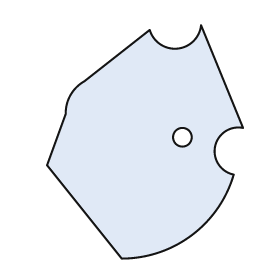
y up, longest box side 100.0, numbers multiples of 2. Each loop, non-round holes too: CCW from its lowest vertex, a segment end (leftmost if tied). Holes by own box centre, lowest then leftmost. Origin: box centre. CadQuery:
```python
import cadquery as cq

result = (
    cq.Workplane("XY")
    .moveTo(-10.0, -50.0)
    .threePointArc((20.0, -40.0), (38.0, -14.0))
    .threePointArc((30.0, -2.0), (42.0, 6.0))
    .lineTo(24.0, 50.0)
    .threePointArc((14.0, 40.0), (2.0, 48.0))
    .lineTo(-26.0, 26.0)
    .threePointArc((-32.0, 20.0), (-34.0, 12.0))
    .lineTo(-42.0, -10.0)
    .close()
    .moveTo(16.0, 2.0)
    .circle(4.0)
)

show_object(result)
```